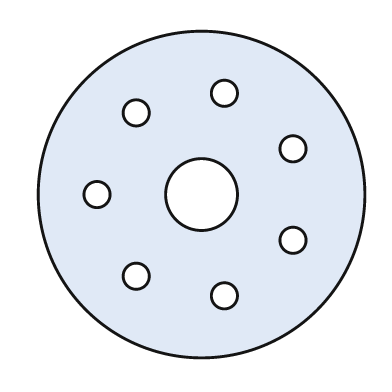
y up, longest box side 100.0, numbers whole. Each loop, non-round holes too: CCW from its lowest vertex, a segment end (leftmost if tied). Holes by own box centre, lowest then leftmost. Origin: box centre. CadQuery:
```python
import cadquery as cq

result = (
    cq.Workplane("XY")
    .moveTo(0.0, 0.0)
    .circle(50.0)
    .moveTo(7.0, -31.0)
    .circle(4.0)
    .moveTo(-20.0, -25.0)
    .circle(4.0)
    .moveTo(28.0, -14.0)
    .circle(4.0)
    .moveTo(-32.0, 0.0)
    .circle(4.0)
    .moveTo(0.0, 0.0)
    .circle(11.0)
    .moveTo(28.0, 14.0)
    .circle(4.0)
    .moveTo(-20.0, 25.0)
    .circle(4.0)
    .moveTo(7.0, 31.0)
    .circle(4.0)
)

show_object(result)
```